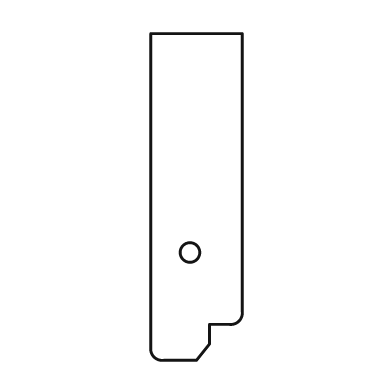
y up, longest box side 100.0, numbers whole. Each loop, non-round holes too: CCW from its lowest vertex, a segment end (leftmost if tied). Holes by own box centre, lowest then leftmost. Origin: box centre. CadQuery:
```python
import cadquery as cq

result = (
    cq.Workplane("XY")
    .moveTo(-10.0, -50.0)
    .lineTo(0.0, -50.0)
    .lineTo(4.0, -45.0)
    .lineTo(4.0, -39.0)
    .lineTo(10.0, -39.0)
    .threePointArc((13.0, -38.0), (14.0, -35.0))
    .lineTo(14.0, 50.0)
    .lineTo(-14.0, 50.0)
    .lineTo(-14.0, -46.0)
    .threePointArc((-13.0, -49.0), (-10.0, -50.0))
    .close()
    .moveTo(-2.0, -17.0)
    .circle(3.0)
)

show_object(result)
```